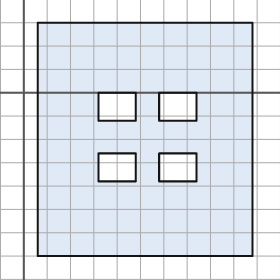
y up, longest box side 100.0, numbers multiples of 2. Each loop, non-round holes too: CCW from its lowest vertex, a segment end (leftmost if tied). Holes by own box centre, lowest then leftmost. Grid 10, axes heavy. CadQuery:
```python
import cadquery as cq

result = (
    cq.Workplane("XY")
    .moveTo(6.0, -70.0)
    .lineTo(98.0, -70.0)
    .lineTo(98.0, 30.0)
    .lineTo(6.0, 30.0)
    .close()
    .moveTo(32.0, -38.0)
    .lineTo(48.0, -38.0)
    .lineTo(48.0, -26.0)
    .lineTo(32.0, -26.0)
    .close()
    .moveTo(58.0, -38.0)
    .lineTo(74.0, -38.0)
    .lineTo(74.0, -26.0)
    .lineTo(58.0, -26.0)
    .close()
    .moveTo(32.0, -12.0)
    .lineTo(48.0, -12.0)
    .lineTo(48.0, 0.0)
    .lineTo(32.0, 0.0)
    .close()
    .moveTo(58.0, -12.0)
    .lineTo(74.0, -12.0)
    .lineTo(74.0, 0.0)
    .lineTo(58.0, 0.0)
    .close()
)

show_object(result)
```